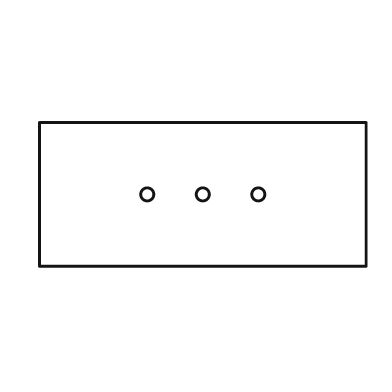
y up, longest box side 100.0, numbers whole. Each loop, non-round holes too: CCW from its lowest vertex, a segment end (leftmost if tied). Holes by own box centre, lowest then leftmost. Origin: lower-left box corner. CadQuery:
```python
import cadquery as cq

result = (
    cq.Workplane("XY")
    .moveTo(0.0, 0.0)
    .lineTo(100.0, 0.0)
    .lineTo(100.0, 44.0)
    .lineTo(0.0, 44.0)
    .close()
    .moveTo(33.0, 22.0)
    .circle(2.0)
    .moveTo(50.0, 22.0)
    .circle(2.0)
    .moveTo(67.0, 22.0)
    .circle(2.0)
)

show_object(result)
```